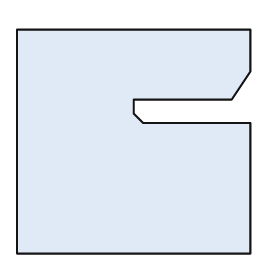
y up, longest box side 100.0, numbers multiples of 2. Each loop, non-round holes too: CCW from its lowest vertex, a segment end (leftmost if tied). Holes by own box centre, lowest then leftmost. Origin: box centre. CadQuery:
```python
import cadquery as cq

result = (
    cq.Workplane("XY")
    .moveTo(-50.0, -48.0)
    .lineTo(50.0, -48.0)
    .lineTo(50.0, 8.0)
    .lineTo(4.0, 8.0)
    .lineTo(0.0, 12.0)
    .lineTo(0.0, 18.0)
    .lineTo(42.0, 18.0)
    .lineTo(50.0, 30.0)
    .lineTo(50.0, 48.0)
    .lineTo(-50.0, 48.0)
    .close()
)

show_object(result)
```